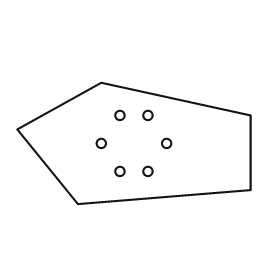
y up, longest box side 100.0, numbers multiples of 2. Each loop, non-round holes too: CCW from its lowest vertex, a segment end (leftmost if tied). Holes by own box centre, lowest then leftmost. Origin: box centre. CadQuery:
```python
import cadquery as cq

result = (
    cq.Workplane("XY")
    .moveTo(-24.0, -26.0)
    .lineTo(50.0, -20.0)
    .lineTo(50.0, 12.0)
    .lineTo(-14.0, 26.0)
    .lineTo(-50.0, 6.0)
    .close()
    .moveTo(-6.0, -12.0)
    .circle(2.0)
    .moveTo(6.0, -12.0)
    .circle(2.0)
    .moveTo(-14.0, 0.0)
    .circle(2.0)
    .moveTo(14.0, 0.0)
    .circle(2.0)
    .moveTo(-6.0, 12.0)
    .circle(2.0)
    .moveTo(6.0, 12.0)
    .circle(2.0)
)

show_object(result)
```